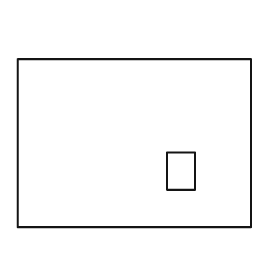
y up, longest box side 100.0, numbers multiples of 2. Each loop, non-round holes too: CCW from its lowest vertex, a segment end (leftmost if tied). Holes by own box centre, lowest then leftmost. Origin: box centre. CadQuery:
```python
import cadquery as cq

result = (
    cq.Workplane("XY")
    .moveTo(-50.0, -36.0)
    .lineTo(50.0, -36.0)
    .lineTo(50.0, 36.0)
    .lineTo(-50.0, 36.0)
    .close()
    .moveTo(14.0, -20.0)
    .lineTo(26.0, -20.0)
    .lineTo(26.0, -4.0)
    .lineTo(14.0, -4.0)
    .close()
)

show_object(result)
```